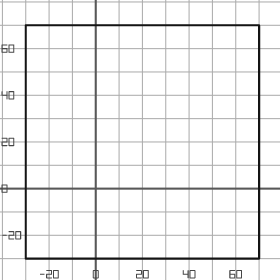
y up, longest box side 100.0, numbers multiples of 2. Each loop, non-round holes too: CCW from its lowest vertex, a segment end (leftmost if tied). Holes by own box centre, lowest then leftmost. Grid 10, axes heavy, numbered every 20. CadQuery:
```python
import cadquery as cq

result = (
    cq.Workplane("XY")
    .moveTo(-30.0, -30.0)
    .lineTo(70.0, -30.0)
    .lineTo(70.0, 70.0)
    .lineTo(-30.0, 70.0)
    .close()
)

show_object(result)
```